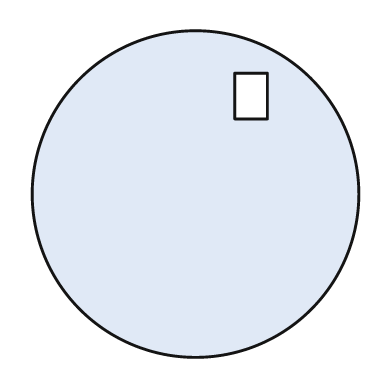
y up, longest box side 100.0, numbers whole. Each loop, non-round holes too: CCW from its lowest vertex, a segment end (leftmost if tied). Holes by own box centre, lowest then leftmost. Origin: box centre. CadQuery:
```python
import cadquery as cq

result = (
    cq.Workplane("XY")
    .moveTo(0.0, 0.0)
    .circle(50.0)
    .moveTo(12.0, 23.0)
    .lineTo(22.0, 23.0)
    .lineTo(22.0, 37.0)
    .lineTo(12.0, 37.0)
    .close()
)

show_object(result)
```